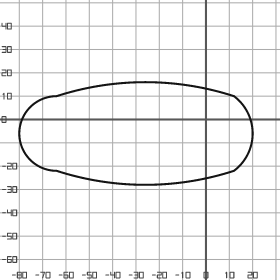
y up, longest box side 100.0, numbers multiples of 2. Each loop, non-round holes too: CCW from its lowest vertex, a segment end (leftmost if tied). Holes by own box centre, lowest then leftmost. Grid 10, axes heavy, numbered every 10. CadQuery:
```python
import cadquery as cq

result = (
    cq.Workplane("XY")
    .moveTo(-64.0, -22.0)
    .threePointArc((-26.0, -28.0), (12.0, -22.0))
    .threePointArc((20.0, -6.0), (12.0, 10.0))
    .threePointArc((-26.0, 16.0), (-64.0, 10.0))
    .threePointArc((-80.0, -6.0), (-64.0, -22.0))
    .close()
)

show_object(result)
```